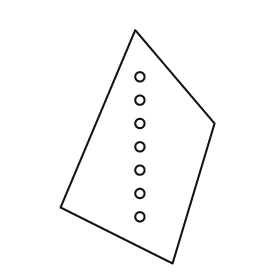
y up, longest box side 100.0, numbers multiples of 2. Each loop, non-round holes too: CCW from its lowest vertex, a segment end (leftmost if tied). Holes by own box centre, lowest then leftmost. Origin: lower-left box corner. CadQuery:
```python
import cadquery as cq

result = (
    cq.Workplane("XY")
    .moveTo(48.0, 0.0)
    .lineTo(66.0, 60.0)
    .lineTo(32.0, 100.0)
    .lineTo(0.0, 24.0)
    .close()
    .moveTo(34.0, 20.0)
    .circle(2.0)
    .moveTo(34.0, 30.0)
    .circle(2.0)
    .moveTo(34.0, 40.0)
    .circle(2.0)
    .moveTo(34.0, 50.0)
    .circle(2.0)
    .moveTo(34.0, 60.0)
    .circle(2.0)
    .moveTo(34.0, 70.0)
    .circle(2.0)
    .moveTo(34.0, 80.0)
    .circle(2.0)
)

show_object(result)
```